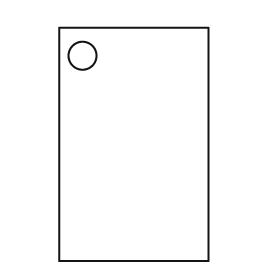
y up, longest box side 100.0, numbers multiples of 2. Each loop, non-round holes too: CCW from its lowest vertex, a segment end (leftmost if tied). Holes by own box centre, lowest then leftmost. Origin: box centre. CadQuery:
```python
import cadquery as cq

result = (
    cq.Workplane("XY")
    .moveTo(-32.0, -50.0)
    .lineTo(32.0, -50.0)
    .lineTo(32.0, 50.0)
    .lineTo(-32.0, 50.0)
    .close()
    .moveTo(-22.0, 38.0)
    .circle(6.0)
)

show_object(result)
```